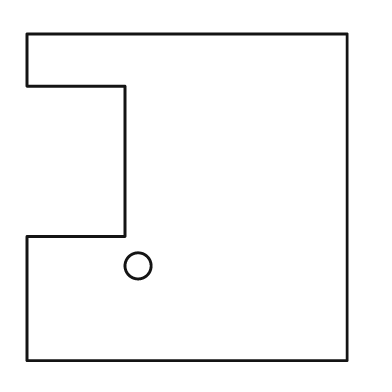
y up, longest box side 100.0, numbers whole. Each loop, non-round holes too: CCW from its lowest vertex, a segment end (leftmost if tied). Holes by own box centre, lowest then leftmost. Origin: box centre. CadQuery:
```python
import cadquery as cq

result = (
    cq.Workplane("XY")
    .moveTo(-49.0, -50.0)
    .lineTo(49.0, -50.0)
    .lineTo(49.0, 50.0)
    .lineTo(-49.0, 50.0)
    .lineTo(-49.0, 34.0)
    .lineTo(-19.0, 34.0)
    .lineTo(-19.0, -12.0)
    .lineTo(-49.0, -12.0)
    .close()
    .moveTo(-15.0, -21.0)
    .circle(4.0)
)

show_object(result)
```